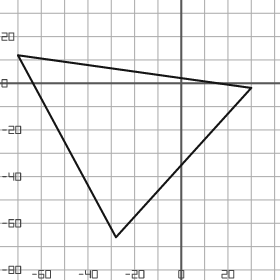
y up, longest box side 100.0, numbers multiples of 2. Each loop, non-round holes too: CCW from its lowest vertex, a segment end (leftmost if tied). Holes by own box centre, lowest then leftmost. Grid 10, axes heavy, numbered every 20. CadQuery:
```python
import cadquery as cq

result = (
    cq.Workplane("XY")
    .moveTo(-28.0, -66.0)
    .lineTo(30.0, -2.0)
    .lineTo(-70.0, 12.0)
    .close()
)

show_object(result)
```